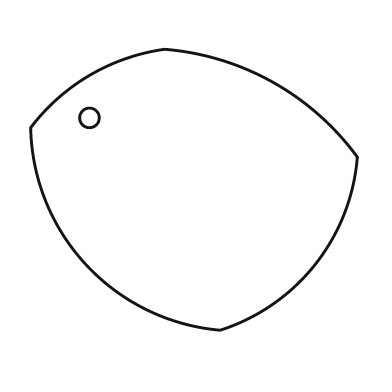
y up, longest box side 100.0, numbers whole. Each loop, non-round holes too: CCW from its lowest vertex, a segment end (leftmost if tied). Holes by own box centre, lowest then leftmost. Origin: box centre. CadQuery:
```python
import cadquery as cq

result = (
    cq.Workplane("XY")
    .moveTo(8.0, -43.0)
    .threePointArc((37.0, -23.0), (50.0, 10.0))
    .threePointArc((24.0, 33.0), (-9.0, 43.0))
    .threePointArc((-32.0, 35.0), (-50.0, 19.0))
    .threePointArc((-33.0, -23.0), (8.0, -43.0))
    .close()
    .moveTo(-32.0, 22.0)
    .circle(3.0)
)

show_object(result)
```